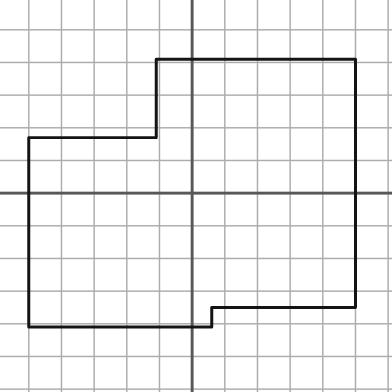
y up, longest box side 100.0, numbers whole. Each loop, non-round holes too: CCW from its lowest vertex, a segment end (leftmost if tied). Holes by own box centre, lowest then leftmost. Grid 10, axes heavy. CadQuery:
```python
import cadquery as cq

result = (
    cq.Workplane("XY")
    .moveTo(-50.0, -41.0)
    .lineTo(6.0, -41.0)
    .lineTo(6.0, -35.0)
    .lineTo(50.0, -35.0)
    .lineTo(50.0, 41.0)
    .lineTo(-11.0, 41.0)
    .lineTo(-11.0, 17.0)
    .lineTo(-50.0, 17.0)
    .close()
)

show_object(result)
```